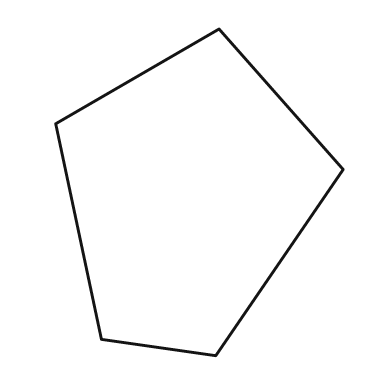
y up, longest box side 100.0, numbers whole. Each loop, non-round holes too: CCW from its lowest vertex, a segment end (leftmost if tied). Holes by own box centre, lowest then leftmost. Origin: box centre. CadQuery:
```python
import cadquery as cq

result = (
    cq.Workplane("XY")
    .moveTo(5.0, -50.0)
    .lineTo(44.0, 7.0)
    .lineTo(6.0, 50.0)
    .lineTo(-44.0, 21.0)
    .lineTo(-30.0, -45.0)
    .close()
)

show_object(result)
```